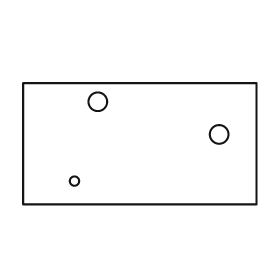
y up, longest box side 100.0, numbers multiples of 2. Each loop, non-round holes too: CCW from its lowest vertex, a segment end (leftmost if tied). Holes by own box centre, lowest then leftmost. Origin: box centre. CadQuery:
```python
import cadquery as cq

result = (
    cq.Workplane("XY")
    .moveTo(-50.0, -26.0)
    .lineTo(50.0, -26.0)
    .lineTo(50.0, 26.0)
    .lineTo(-50.0, 26.0)
    .close()
    .moveTo(-28.0, -16.0)
    .circle(2.0)
    .moveTo(34.0, 4.0)
    .circle(4.0)
    .moveTo(-18.0, 18.0)
    .circle(4.0)
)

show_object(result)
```